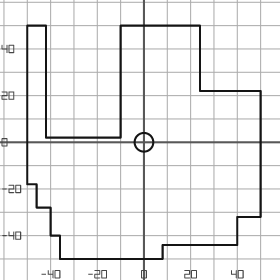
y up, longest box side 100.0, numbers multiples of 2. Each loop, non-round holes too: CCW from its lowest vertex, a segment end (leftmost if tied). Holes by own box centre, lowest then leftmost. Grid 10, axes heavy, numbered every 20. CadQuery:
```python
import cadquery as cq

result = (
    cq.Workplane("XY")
    .moveTo(-36.0, -50.0)
    .lineTo(8.0, -50.0)
    .lineTo(8.0, -44.0)
    .lineTo(40.0, -44.0)
    .lineTo(40.0, -32.0)
    .lineTo(50.0, -32.0)
    .lineTo(50.0, 22.0)
    .lineTo(24.0, 22.0)
    .lineTo(24.0, 50.0)
    .lineTo(-10.0, 50.0)
    .lineTo(-10.0, 2.0)
    .lineTo(-42.0, 2.0)
    .lineTo(-42.0, 50.0)
    .lineTo(-50.0, 50.0)
    .lineTo(-50.0, -18.0)
    .lineTo(-46.0, -18.0)
    .lineTo(-46.0, -28.0)
    .lineTo(-40.0, -28.0)
    .lineTo(-40.0, -40.0)
    .lineTo(-36.0, -40.0)
    .close()
    .moveTo(0.0, 0.0)
    .circle(4.0)
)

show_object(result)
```